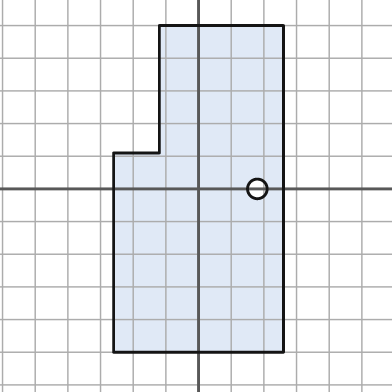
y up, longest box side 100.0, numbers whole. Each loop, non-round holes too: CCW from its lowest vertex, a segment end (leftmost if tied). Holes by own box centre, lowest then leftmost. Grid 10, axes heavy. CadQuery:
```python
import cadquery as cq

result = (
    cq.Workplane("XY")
    .moveTo(-26.0, -50.0)
    .lineTo(26.0, -50.0)
    .lineTo(26.0, 50.0)
    .lineTo(-12.0, 50.0)
    .lineTo(-12.0, 11.0)
    .lineTo(-26.0, 11.0)
    .close()
    .moveTo(18.0, 0.0)
    .circle(3.0)
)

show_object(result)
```